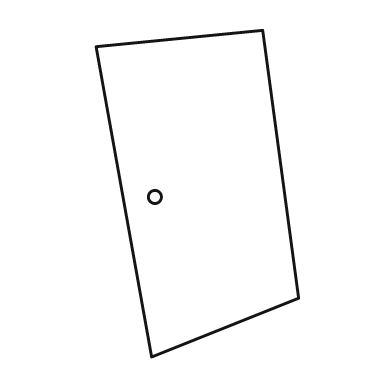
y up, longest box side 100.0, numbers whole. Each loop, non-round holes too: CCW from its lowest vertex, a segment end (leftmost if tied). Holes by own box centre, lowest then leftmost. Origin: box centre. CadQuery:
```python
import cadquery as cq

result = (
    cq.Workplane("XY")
    .moveTo(-14.0, -50.0)
    .lineTo(31.0, -32.0)
    .lineTo(20.0, 50.0)
    .lineTo(-31.0, 45.0)
    .close()
    .moveTo(-13.0, -1.0)
    .circle(2.0)
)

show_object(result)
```